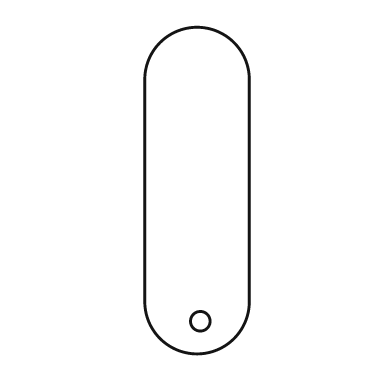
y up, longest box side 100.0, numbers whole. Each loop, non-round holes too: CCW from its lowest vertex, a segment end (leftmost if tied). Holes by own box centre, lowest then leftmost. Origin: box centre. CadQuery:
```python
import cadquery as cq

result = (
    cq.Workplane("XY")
    .moveTo(-16.0, -34.0)
    .threePointArc((0.0, -50.0), (16.0, -34.0))
    .lineTo(16.0, 34.0)
    .threePointArc((0.0, 50.0), (-16.0, 34.0))
    .close()
    .moveTo(1.0, -40.0)
    .circle(3.0)
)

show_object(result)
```